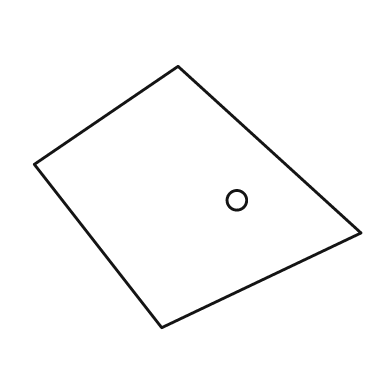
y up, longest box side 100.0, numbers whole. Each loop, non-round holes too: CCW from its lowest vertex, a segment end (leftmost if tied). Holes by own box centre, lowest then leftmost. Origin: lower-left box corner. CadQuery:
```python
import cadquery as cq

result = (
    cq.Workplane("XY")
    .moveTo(39.0, 0.0)
    .lineTo(100.0, 29.0)
    .lineTo(44.0, 80.0)
    .lineTo(0.0, 50.0)
    .close()
    .moveTo(62.0, 39.0)
    .circle(3.0)
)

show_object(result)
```